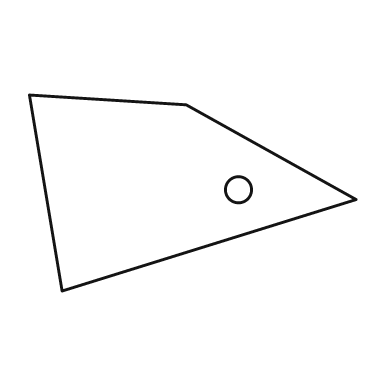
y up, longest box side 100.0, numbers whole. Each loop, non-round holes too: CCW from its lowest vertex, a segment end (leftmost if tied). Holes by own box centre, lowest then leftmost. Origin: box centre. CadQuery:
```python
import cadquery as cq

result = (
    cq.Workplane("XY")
    .moveTo(-40.0, -30.0)
    .lineTo(50.0, -2.0)
    .lineTo(-2.0, 27.0)
    .lineTo(-50.0, 30.0)
    .close()
    .moveTo(14.0, 1.0)
    .circle(4.0)
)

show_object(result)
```